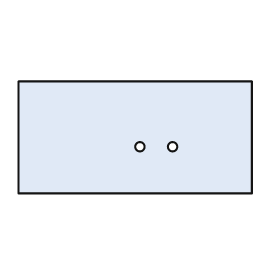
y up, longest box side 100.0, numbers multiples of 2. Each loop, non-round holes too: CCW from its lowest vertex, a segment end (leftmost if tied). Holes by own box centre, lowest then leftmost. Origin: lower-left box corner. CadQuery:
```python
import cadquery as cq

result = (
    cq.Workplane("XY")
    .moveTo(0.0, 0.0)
    .lineTo(100.0, 0.0)
    .lineTo(100.0, 48.0)
    .lineTo(0.0, 48.0)
    .close()
    .moveTo(52.0, 20.0)
    .circle(2.0)
    .moveTo(66.0, 20.0)
    .circle(2.0)
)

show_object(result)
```